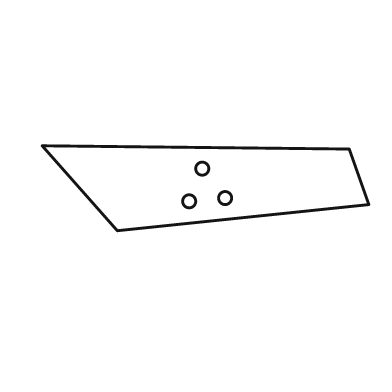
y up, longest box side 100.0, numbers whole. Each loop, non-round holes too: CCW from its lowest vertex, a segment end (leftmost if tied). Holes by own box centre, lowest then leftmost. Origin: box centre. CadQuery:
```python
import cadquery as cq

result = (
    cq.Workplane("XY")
    .moveTo(-27.0, -13.0)
    .lineTo(50.0, -5.0)
    .lineTo(44.0, 12.0)
    .lineTo(-50.0, 13.0)
    .close()
    .moveTo(-5.0, -4.0)
    .circle(2.0)
    .moveTo(6.0, -3.0)
    .circle(2.0)
    .moveTo(-1.0, 6.0)
    .circle(2.0)
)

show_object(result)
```